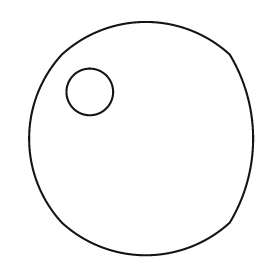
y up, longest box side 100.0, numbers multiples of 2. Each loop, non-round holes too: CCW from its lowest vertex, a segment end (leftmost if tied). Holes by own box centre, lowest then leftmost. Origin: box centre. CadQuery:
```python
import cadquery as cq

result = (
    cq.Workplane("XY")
    .moveTo(-34.0, -36.0)
    .threePointArc((2.0, -50.0), (38.0, -36.0))
    .threePointArc((48.0, 0.0), (38.0, 36.0))
    .threePointArc((2.0, 50.0), (-34.0, 36.0))
    .threePointArc((-48.0, 0.0), (-34.0, -36.0))
    .close()
    .moveTo(-22.0, 20.0)
    .circle(10.0)
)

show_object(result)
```